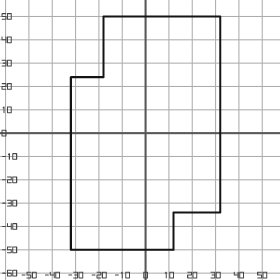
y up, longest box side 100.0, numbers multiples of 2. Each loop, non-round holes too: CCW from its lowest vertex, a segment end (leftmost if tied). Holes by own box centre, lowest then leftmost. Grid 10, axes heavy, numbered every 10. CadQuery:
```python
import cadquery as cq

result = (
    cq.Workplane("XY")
    .moveTo(-32.0, -50.0)
    .lineTo(12.0, -50.0)
    .lineTo(12.0, -34.0)
    .lineTo(32.0, -34.0)
    .lineTo(32.0, 50.0)
    .lineTo(-18.0, 50.0)
    .lineTo(-18.0, 24.0)
    .lineTo(-32.0, 24.0)
    .close()
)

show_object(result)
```